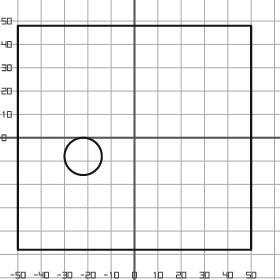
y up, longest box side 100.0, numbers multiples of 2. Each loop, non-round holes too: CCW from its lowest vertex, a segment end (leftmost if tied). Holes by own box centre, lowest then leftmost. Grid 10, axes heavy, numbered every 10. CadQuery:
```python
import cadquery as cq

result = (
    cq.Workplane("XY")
    .moveTo(-50.0, -48.0)
    .lineTo(50.0, -48.0)
    .lineTo(50.0, 48.0)
    .lineTo(-50.0, 48.0)
    .close()
    .moveTo(-22.0, -8.0)
    .circle(8.0)
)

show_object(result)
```